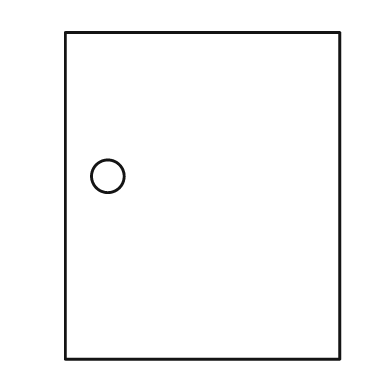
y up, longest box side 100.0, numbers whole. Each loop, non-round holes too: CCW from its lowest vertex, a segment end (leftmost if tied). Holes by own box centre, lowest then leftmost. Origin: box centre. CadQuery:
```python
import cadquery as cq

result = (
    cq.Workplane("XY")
    .moveTo(-42.0, -50.0)
    .lineTo(42.0, -50.0)
    .lineTo(42.0, 50.0)
    .lineTo(-42.0, 50.0)
    .close()
    .moveTo(-29.0, 6.0)
    .circle(5.0)
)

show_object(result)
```